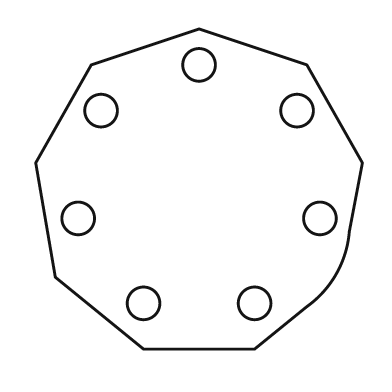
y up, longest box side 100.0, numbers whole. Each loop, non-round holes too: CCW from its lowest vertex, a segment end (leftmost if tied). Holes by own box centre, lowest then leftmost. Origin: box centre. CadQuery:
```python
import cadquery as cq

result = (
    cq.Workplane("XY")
    .moveTo(-17.0, -49.0)
    .lineTo(17.0, -49.0)
    .lineTo(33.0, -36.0)
    .threePointArc((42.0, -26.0), (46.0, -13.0))
    .lineTo(50.0, 8.0)
    .lineTo(33.0, 38.0)
    .lineTo(0.0, 49.0)
    .lineTo(-33.0, 38.0)
    .lineTo(-50.0, 8.0)
    .lineTo(-44.0, -27.0)
    .close()
    .moveTo(-17.0, -35.0)
    .circle(5.0)
    .moveTo(17.0, -35.0)
    .circle(5.0)
    .moveTo(-37.0, -9.0)
    .circle(5.0)
    .moveTo(37.0, -9.0)
    .circle(5.0)
    .moveTo(-30.0, 24.0)
    .circle(5.0)
    .moveTo(30.0, 24.0)
    .circle(5.0)
    .moveTo(0.0, 38.0)
    .circle(5.0)
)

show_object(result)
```